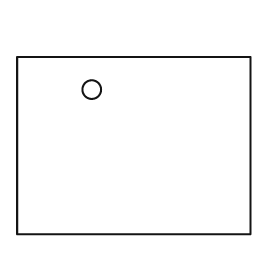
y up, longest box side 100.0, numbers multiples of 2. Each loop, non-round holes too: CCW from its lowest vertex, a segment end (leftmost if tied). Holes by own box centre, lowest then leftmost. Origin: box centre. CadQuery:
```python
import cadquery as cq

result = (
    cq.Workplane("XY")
    .moveTo(-50.0, -38.0)
    .lineTo(50.0, -38.0)
    .lineTo(50.0, 38.0)
    .lineTo(-50.0, 38.0)
    .close()
    .moveTo(-18.0, 24.0)
    .circle(4.0)
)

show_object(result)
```